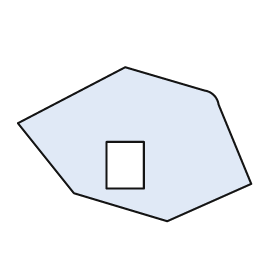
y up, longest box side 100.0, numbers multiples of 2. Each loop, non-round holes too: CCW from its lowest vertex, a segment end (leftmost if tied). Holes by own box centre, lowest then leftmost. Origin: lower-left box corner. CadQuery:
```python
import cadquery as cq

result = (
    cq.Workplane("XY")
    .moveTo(64.0, 0.0)
    .lineTo(100.0, 16.0)
    .lineTo(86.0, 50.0)
    .threePointArc((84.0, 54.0), (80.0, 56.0))
    .lineTo(46.0, 66.0)
    .lineTo(0.0, 42.0)
    .lineTo(24.0, 12.0)
    .close()
    .moveTo(38.0, 14.0)
    .lineTo(54.0, 14.0)
    .lineTo(54.0, 34.0)
    .lineTo(38.0, 34.0)
    .close()
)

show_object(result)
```